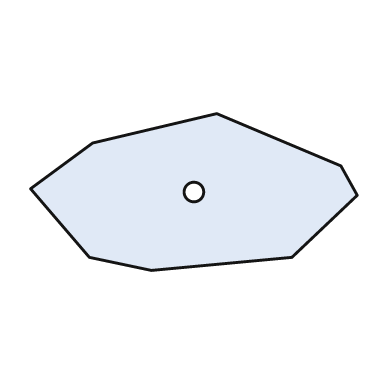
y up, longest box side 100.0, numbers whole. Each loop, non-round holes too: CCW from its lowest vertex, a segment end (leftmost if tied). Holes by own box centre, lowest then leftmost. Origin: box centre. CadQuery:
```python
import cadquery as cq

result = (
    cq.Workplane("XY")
    .moveTo(-13.0, -24.0)
    .lineTo(30.0, -20.0)
    .lineTo(50.0, -1.0)
    .lineTo(45.0, 8.0)
    .lineTo(7.0, 24.0)
    .lineTo(-31.0, 15.0)
    .lineTo(-50.0, 1.0)
    .lineTo(-32.0, -20.0)
    .close()
    .moveTo(0.0, 0.0)
    .circle(3.0)
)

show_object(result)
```